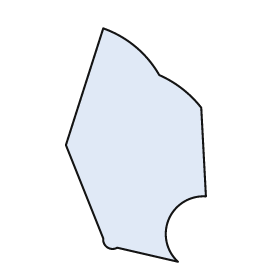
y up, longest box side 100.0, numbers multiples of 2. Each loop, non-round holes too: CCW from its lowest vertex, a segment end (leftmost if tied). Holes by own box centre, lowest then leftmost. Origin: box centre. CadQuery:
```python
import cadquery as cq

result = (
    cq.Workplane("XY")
    .moveTo(18.0, -50.0)
    .threePointArc((14.0, -32.0), (30.0, -22.0))
    .lineTo(28.0, 16.0)
    .threePointArc((20.0, 24.0), (10.0, 30.0))
    .threePointArc((0.0, 42.0), (-14.0, 50.0))
    .lineTo(-30.0, 0.0)
    .lineTo(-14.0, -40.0)
    .threePointArc((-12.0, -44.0), (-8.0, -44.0))
    .close()
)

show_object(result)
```